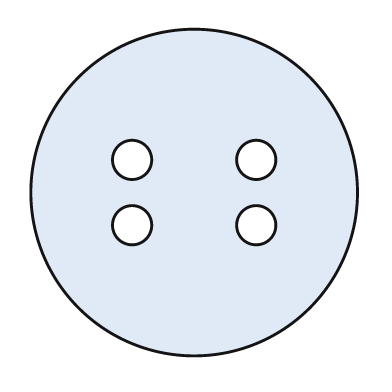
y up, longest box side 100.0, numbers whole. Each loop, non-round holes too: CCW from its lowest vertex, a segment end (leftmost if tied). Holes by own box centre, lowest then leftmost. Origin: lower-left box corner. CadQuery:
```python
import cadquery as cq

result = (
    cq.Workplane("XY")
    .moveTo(50.0, 50.0)
    .circle(50.0)
    .moveTo(31.0, 40.0)
    .circle(6.0)
    .moveTo(69.0, 40.0)
    .circle(6.0)
    .moveTo(31.0, 60.0)
    .circle(6.0)
    .moveTo(69.0, 60.0)
    .circle(6.0)
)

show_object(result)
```